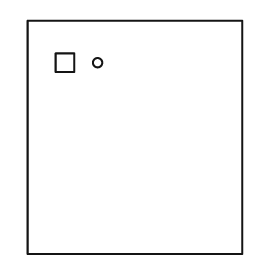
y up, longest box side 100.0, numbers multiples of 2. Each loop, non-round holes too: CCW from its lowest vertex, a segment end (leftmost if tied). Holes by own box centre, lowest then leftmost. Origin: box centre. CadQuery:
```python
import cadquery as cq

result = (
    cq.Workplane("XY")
    .moveTo(-46.0, -50.0)
    .lineTo(46.0, -50.0)
    .lineTo(46.0, 50.0)
    .lineTo(-46.0, 50.0)
    .close()
    .moveTo(-34.0, 28.0)
    .lineTo(-26.0, 28.0)
    .lineTo(-26.0, 36.0)
    .lineTo(-34.0, 36.0)
    .close()
    .moveTo(-16.0, 32.0)
    .circle(2.0)
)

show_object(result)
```